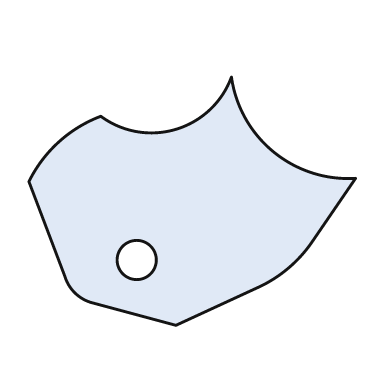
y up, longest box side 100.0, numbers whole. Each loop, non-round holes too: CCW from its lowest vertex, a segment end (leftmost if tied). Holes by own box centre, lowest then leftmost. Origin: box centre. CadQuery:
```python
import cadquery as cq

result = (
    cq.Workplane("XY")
    .moveTo(-5.0, -38.0)
    .lineTo(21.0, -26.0)
    .threePointArc((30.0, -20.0), (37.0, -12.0))
    .lineTo(50.0, 7.0)
    .threePointArc((25.0, 15.0), (12.0, 38.0))
    .threePointArc((-5.0, 22.0), (-28.0, 26.0))
    .threePointArc((-41.0, 18.0), (-50.0, 6.0))
    .lineTo(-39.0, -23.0)
    .threePointArc((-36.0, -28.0), (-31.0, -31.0))
    .close()
    .moveTo(-17.0, -18.0)
    .circle(6.0)
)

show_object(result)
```